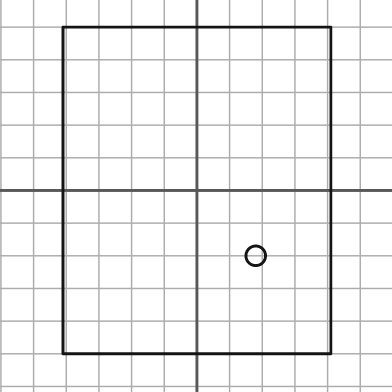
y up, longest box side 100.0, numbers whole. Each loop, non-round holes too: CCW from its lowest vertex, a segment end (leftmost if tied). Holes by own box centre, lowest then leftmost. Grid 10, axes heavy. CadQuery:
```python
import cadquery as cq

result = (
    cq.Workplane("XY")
    .moveTo(-41.0, -50.0)
    .lineTo(41.0, -50.0)
    .lineTo(41.0, 50.0)
    .lineTo(-41.0, 50.0)
    .close()
    .moveTo(18.0, -20.0)
    .circle(3.0)
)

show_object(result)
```